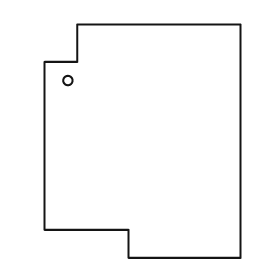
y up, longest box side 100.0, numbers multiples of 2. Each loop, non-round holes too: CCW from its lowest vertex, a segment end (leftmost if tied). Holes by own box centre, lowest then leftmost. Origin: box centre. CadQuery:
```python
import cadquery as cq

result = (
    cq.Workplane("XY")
    .moveTo(-6.0, -50.0)
    .lineTo(42.0, -50.0)
    .lineTo(42.0, 50.0)
    .lineTo(-28.0, 50.0)
    .lineTo(-28.0, 34.0)
    .lineTo(-42.0, 34.0)
    .lineTo(-42.0, -38.0)
    .lineTo(-6.0, -38.0)
    .close()
    .moveTo(-32.0, 26.0)
    .circle(2.0)
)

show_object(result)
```